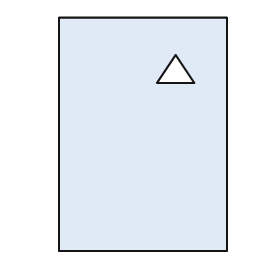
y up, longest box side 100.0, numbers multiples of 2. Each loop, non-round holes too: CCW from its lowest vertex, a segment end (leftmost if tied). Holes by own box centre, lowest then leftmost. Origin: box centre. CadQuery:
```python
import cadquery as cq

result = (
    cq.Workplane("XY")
    .moveTo(-36.0, -50.0)
    .lineTo(36.0, -50.0)
    .lineTo(36.0, 50.0)
    .lineTo(-36.0, 50.0)
    .close()
    .moveTo(6.0, 22.0)
    .lineTo(22.0, 22.0)
    .lineTo(14.0, 34.0)
    .close()
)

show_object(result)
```